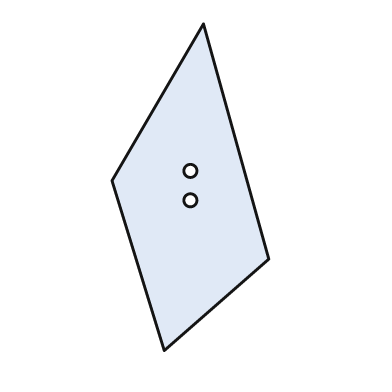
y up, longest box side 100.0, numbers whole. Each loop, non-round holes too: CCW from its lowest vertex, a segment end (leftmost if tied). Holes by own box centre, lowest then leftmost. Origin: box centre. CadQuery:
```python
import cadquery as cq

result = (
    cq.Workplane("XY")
    .moveTo(-8.0, -50.0)
    .lineTo(24.0, -22.0)
    .lineTo(4.0, 50.0)
    .lineTo(-24.0, 2.0)
    .close()
    .moveTo(0.0, -4.0)
    .circle(2.0)
    .moveTo(0.0, 5.0)
    .circle(2.0)
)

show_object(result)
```